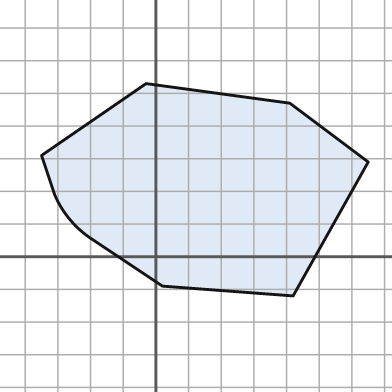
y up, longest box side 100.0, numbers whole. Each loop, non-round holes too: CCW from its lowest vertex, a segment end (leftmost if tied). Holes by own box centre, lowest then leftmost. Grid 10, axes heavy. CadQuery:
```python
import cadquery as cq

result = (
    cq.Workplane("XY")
    .moveTo(42.0, -12.0)
    .lineTo(65.0, 29.0)
    .lineTo(41.0, 47.0)
    .lineTo(-3.0, 53.0)
    .lineTo(-35.0, 31.0)
    .lineTo(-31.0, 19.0)
    .threePointArc((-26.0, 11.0), (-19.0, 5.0))
    .lineTo(2.0, -9.0)
    .close()
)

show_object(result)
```